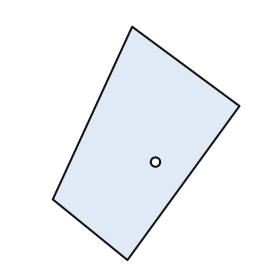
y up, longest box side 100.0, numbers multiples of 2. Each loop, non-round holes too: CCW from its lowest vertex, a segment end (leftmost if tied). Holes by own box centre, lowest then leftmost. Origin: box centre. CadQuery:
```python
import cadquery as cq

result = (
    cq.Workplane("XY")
    .moveTo(-8.0, -50.0)
    .lineTo(40.0, 16.0)
    .lineTo(-6.0, 50.0)
    .lineTo(-40.0, -24.0)
    .close()
    .moveTo(4.0, -8.0)
    .circle(2.0)
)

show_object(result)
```